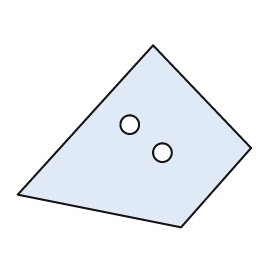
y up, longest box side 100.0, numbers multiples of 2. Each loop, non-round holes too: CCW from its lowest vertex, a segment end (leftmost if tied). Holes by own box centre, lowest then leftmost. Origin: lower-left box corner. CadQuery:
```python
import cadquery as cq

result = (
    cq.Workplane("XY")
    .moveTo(70.0, 0.0)
    .lineTo(100.0, 34.0)
    .lineTo(58.0, 78.0)
    .lineTo(0.0, 14.0)
    .close()
    .moveTo(62.0, 32.0)
    .circle(4.0)
    .moveTo(48.0, 44.0)
    .circle(4.0)
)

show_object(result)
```